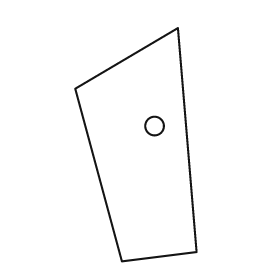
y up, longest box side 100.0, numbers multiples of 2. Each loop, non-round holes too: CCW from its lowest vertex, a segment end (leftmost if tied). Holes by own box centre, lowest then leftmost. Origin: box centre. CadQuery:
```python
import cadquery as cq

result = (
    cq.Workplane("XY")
    .moveTo(-6.0, -50.0)
    .lineTo(26.0, -46.0)
    .lineTo(18.0, 50.0)
    .lineTo(-26.0, 24.0)
    .close()
    .moveTo(8.0, 8.0)
    .circle(4.0)
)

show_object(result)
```